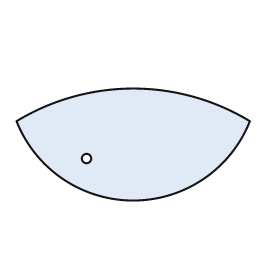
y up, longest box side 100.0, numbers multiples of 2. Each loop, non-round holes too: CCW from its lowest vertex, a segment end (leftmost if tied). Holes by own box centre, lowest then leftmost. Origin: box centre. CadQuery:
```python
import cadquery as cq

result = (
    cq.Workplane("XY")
    .moveTo(-50.0, 10.0)
    .threePointArc((0.0, -24.0), (50.0, 10.0))
    .threePointArc((0.0, 24.0), (-50.0, 10.0))
    .close()
    .moveTo(-20.0, -6.0)
    .circle(2.0)
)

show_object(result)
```